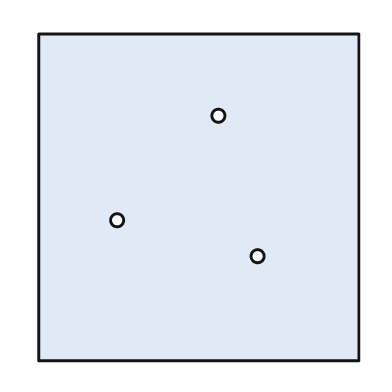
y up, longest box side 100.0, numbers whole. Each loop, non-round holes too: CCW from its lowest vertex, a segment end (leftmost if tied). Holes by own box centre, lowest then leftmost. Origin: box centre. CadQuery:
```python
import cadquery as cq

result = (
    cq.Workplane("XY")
    .moveTo(-49.0, -50.0)
    .lineTo(49.0, -50.0)
    .lineTo(49.0, 50.0)
    .lineTo(-49.0, 50.0)
    .close()
    .moveTo(18.0, -18.0)
    .circle(2.0)
    .moveTo(-25.0, -7.0)
    .circle(2.0)
    .moveTo(6.0, 25.0)
    .circle(2.0)
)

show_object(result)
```